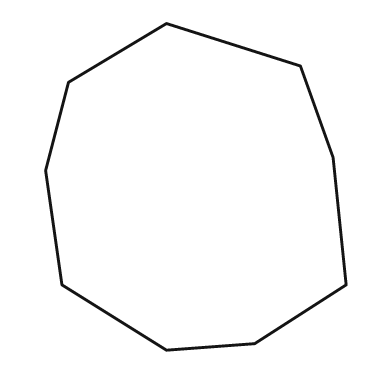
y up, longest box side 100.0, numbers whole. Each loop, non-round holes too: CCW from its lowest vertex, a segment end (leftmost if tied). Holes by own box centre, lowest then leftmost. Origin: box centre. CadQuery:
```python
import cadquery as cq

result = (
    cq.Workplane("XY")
    .moveTo(-9.0, -50.0)
    .lineTo(18.0, -48.0)
    .lineTo(46.0, -30.0)
    .lineTo(42.0, 9.0)
    .lineTo(32.0, 37.0)
    .lineTo(-9.0, 50.0)
    .lineTo(-39.0, 32.0)
    .lineTo(-46.0, 5.0)
    .lineTo(-41.0, -30.0)
    .close()
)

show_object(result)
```